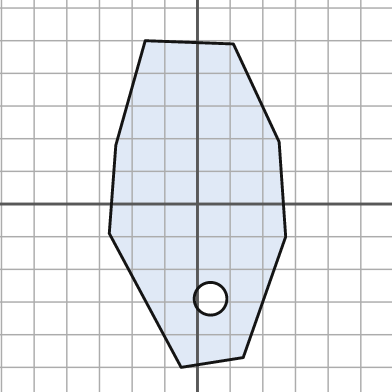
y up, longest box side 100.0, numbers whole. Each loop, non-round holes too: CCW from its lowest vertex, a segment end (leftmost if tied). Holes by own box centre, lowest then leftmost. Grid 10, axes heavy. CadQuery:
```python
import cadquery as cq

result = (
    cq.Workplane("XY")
    .moveTo(-5.0, -50.0)
    .lineTo(14.0, -47.0)
    .lineTo(27.0, -10.0)
    .lineTo(25.0, 19.0)
    .lineTo(11.0, 49.0)
    .lineTo(-16.0, 50.0)
    .lineTo(-25.0, 18.0)
    .lineTo(-27.0, -9.0)
    .close()
    .moveTo(4.0, -29.0)
    .circle(5.0)
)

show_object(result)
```